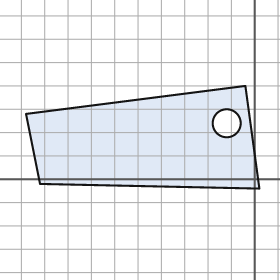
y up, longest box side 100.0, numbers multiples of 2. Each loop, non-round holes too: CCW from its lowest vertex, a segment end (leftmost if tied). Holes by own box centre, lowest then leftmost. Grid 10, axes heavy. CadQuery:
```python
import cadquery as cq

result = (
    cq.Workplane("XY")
    .moveTo(2.0, -4.0)
    .lineTo(-4.0, 40.0)
    .lineTo(-98.0, 28.0)
    .lineTo(-92.0, -2.0)
    .close()
    .moveTo(-12.0, 24.0)
    .circle(6.0)
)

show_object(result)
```